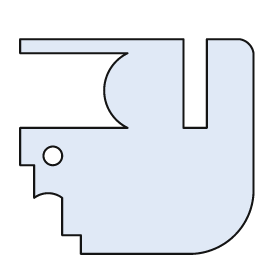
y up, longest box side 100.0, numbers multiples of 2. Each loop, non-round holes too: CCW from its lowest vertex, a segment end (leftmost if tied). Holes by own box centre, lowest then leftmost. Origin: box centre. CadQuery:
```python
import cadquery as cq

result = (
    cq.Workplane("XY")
    .moveTo(-24.0, -46.0)
    .lineTo(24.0, -46.0)
    .threePointArc((42.0, -38.0), (50.0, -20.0))
    .lineTo(50.0, 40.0)
    .threePointArc((48.0, 44.0), (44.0, 46.0))
    .lineTo(30.0, 46.0)
    .lineTo(30.0, 8.0)
    .lineTo(20.0, 8.0)
    .lineTo(20.0, 46.0)
    .lineTo(-50.0, 46.0)
    .lineTo(-50.0, 40.0)
    .lineTo(-4.0, 40.0)
    .threePointArc((-14.0, 24.0), (-4.0, 8.0))
    .lineTo(-50.0, 8.0)
    .lineTo(-50.0, -8.0)
    .lineTo(-44.0, -8.0)
    .lineTo(-44.0, -22.0)
    .threePointArc((-38.0, -20.0), (-32.0, -22.0))
    .lineTo(-32.0, -38.0)
    .lineTo(-24.0, -38.0)
    .close()
    .moveTo(-36.0, -4.0)
    .circle(4.0)
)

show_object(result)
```